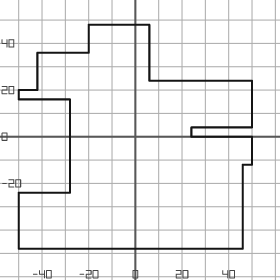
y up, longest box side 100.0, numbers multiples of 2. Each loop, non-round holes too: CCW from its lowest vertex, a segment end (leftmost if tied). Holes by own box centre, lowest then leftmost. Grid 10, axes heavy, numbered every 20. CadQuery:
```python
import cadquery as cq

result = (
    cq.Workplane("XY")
    .moveTo(-50.0, -48.0)
    .lineTo(46.0, -48.0)
    .lineTo(46.0, -12.0)
    .lineTo(50.0, -12.0)
    .lineTo(50.0, 0.0)
    .lineTo(24.0, 0.0)
    .lineTo(24.0, 4.0)
    .lineTo(50.0, 4.0)
    .lineTo(50.0, 24.0)
    .lineTo(6.0, 24.0)
    .lineTo(6.0, 48.0)
    .lineTo(-20.0, 48.0)
    .lineTo(-20.0, 36.0)
    .lineTo(-42.0, 36.0)
    .lineTo(-42.0, 20.0)
    .lineTo(-50.0, 20.0)
    .lineTo(-50.0, 16.0)
    .lineTo(-28.0, 16.0)
    .lineTo(-28.0, -24.0)
    .lineTo(-50.0, -24.0)
    .close()
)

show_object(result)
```